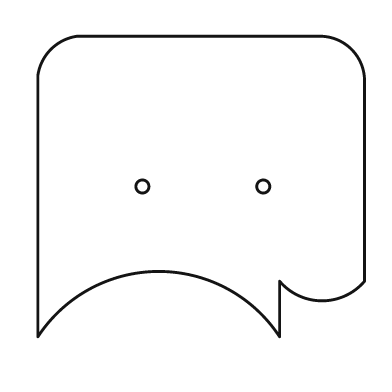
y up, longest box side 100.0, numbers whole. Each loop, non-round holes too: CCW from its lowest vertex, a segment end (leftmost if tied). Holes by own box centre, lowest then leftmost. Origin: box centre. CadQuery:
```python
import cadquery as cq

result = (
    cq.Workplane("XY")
    .moveTo(-50.0, -46.0)
    .threePointArc((-13.0, -26.0), (24.0, -46.0))
    .lineTo(24.0, -29.0)
    .threePointArc((37.0, -35.0), (50.0, -29.0))
    .lineTo(50.0, 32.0)
    .threePointArc((46.0, 42.0), (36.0, 46.0))
    .lineTo(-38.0, 46.0)
    .threePointArc((-46.0, 42.0), (-50.0, 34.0))
    .close()
    .moveTo(-18.0, 0.0)
    .circle(2.0)
    .moveTo(19.0, 0.0)
    .circle(2.0)
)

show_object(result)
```